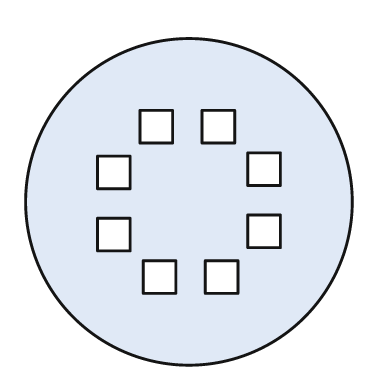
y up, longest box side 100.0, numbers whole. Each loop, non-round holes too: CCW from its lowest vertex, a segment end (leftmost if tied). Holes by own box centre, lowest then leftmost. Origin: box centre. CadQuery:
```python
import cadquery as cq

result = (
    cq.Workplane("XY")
    .moveTo(0.0, 0.0)
    .circle(50.0)
    .moveTo(-14.0, -28.0)
    .lineTo(-4.0, -28.0)
    .lineTo(-4.0, -18.0)
    .lineTo(-14.0, -18.0)
    .close()
    .moveTo(5.0, -28.0)
    .lineTo(15.0, -28.0)
    .lineTo(15.0, -18.0)
    .lineTo(5.0, -18.0)
    .close()
    .moveTo(-28.0, -15.0)
    .lineTo(-18.0, -15.0)
    .lineTo(-18.0, -5.0)
    .lineTo(-28.0, -5.0)
    .close()
    .moveTo(18.0, -14.0)
    .lineTo(28.0, -14.0)
    .lineTo(28.0, -4.0)
    .lineTo(18.0, -4.0)
    .close()
    .moveTo(-28.0, 4.0)
    .lineTo(-18.0, 4.0)
    .lineTo(-18.0, 14.0)
    .lineTo(-28.0, 14.0)
    .close()
    .moveTo(18.0, 5.0)
    .lineTo(28.0, 5.0)
    .lineTo(28.0, 15.0)
    .lineTo(18.0, 15.0)
    .close()
    .moveTo(-15.0, 18.0)
    .lineTo(-5.0, 18.0)
    .lineTo(-5.0, 28.0)
    .lineTo(-15.0, 28.0)
    .close()
    .moveTo(4.0, 18.0)
    .lineTo(14.0, 18.0)
    .lineTo(14.0, 28.0)
    .lineTo(4.0, 28.0)
    .close()
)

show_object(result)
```